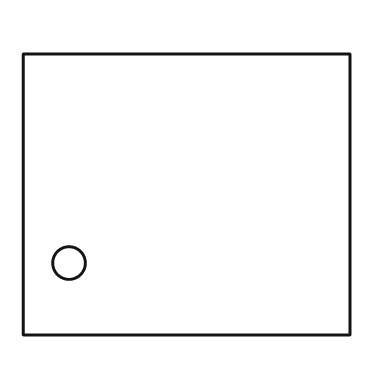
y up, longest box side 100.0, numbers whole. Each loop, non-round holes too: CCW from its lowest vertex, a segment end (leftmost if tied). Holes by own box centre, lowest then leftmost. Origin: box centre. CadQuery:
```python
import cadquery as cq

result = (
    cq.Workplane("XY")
    .moveTo(-50.0, -43.0)
    .lineTo(50.0, -43.0)
    .lineTo(50.0, 43.0)
    .lineTo(-50.0, 43.0)
    .close()
    .moveTo(-36.0, -21.0)
    .circle(5.0)
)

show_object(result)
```